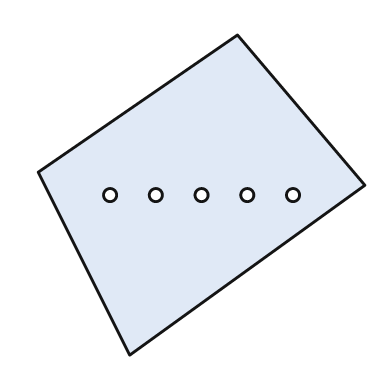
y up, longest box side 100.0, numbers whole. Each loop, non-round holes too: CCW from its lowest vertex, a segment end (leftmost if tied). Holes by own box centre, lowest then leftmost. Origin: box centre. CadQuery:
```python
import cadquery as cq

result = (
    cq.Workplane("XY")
    .moveTo(-22.0, -49.0)
    .lineTo(50.0, 3.0)
    .lineTo(11.0, 49.0)
    .lineTo(-50.0, 7.0)
    .close()
    .moveTo(-28.0, 0.0)
    .circle(2.0)
    .moveTo(-14.0, 0.0)
    .circle(2.0)
    .moveTo(0.0, 0.0)
    .circle(2.0)
    .moveTo(14.0, 0.0)
    .circle(2.0)
    .moveTo(28.0, 0.0)
    .circle(2.0)
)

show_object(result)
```